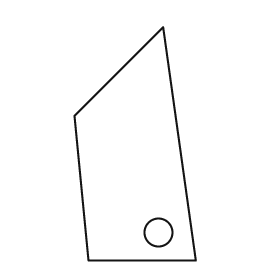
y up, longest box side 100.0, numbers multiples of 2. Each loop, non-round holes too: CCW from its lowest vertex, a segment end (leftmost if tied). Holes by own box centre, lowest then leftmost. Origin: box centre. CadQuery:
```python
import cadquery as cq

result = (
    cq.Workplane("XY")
    .moveTo(-20.0, -50.0)
    .lineTo(26.0, -50.0)
    .lineTo(12.0, 50.0)
    .lineTo(-26.0, 12.0)
    .close()
    .moveTo(10.0, -38.0)
    .circle(6.0)
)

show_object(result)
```